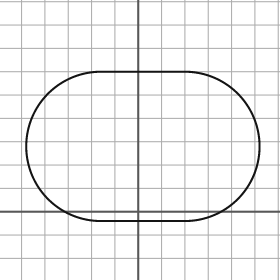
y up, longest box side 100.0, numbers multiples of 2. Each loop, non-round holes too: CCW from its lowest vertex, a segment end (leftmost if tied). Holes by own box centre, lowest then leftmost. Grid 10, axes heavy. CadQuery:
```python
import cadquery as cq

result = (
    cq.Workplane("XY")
    .moveTo(-16.0, -4.0)
    .lineTo(20.0, -4.0)
    .threePointArc((52.0, 28.0), (20.0, 60.0))
    .lineTo(-16.0, 60.0)
    .threePointArc((-48.0, 28.0), (-16.0, -4.0))
    .close()
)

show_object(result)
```